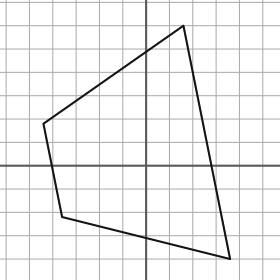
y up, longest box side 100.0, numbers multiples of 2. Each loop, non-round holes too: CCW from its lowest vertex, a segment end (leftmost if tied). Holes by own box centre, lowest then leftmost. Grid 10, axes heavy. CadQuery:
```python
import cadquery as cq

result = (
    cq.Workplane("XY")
    .moveTo(36.0, -40.0)
    .lineTo(16.0, 60.0)
    .lineTo(-44.0, 18.0)
    .lineTo(-36.0, -22.0)
    .close()
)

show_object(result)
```